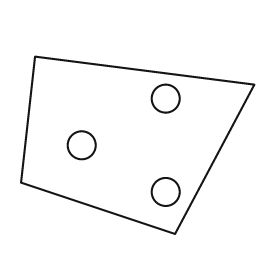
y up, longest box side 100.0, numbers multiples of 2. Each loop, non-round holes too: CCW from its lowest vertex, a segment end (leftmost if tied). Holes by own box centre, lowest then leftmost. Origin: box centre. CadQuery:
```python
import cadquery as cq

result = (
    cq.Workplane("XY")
    .moveTo(16.0, -38.0)
    .lineTo(50.0, 26.0)
    .lineTo(-44.0, 38.0)
    .lineTo(-50.0, -16.0)
    .close()
    .moveTo(12.0, -20.0)
    .circle(6.0)
    .moveTo(-24.0, 0.0)
    .circle(6.0)
    .moveTo(12.0, 20.0)
    .circle(6.0)
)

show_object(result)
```